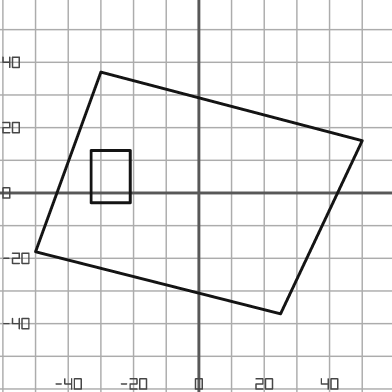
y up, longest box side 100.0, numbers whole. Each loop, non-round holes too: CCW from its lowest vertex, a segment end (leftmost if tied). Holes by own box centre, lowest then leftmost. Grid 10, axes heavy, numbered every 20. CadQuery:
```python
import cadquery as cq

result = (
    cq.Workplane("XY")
    .moveTo(25.0, -37.0)
    .lineTo(50.0, 16.0)
    .lineTo(-30.0, 37.0)
    .lineTo(-50.0, -18.0)
    .close()
    .moveTo(-33.0, -3.0)
    .lineTo(-21.0, -3.0)
    .lineTo(-21.0, 13.0)
    .lineTo(-33.0, 13.0)
    .close()
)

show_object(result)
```